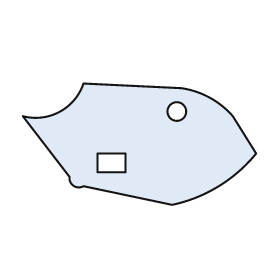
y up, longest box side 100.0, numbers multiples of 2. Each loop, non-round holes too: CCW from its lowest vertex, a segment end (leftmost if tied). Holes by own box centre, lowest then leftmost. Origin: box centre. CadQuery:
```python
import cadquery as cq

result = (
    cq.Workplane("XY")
    .moveTo(14.0, -26.0)
    .threePointArc((34.0, -18.0), (50.0, -4.0))
    .lineTo(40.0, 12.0)
    .threePointArc((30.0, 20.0), (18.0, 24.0))
    .lineTo(-24.0, 26.0)
    .threePointArc((-34.0, 14.0), (-50.0, 12.0))
    .lineTo(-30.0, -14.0)
    .threePointArc((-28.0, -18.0), (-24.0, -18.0))
    .close()
    .moveTo(-18.0, -12.0)
    .lineTo(-6.0, -12.0)
    .lineTo(-6.0, -4.0)
    .lineTo(-18.0, -4.0)
    .close()
    .moveTo(16.0, 14.0)
    .circle(4.0)
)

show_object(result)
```